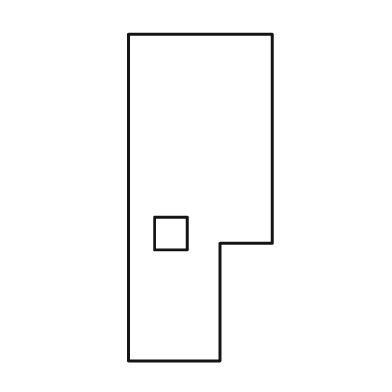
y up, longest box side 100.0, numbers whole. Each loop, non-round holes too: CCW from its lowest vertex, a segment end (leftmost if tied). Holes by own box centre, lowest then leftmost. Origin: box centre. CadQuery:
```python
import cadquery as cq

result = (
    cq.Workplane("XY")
    .moveTo(-22.0, -50.0)
    .lineTo(6.0, -50.0)
    .lineTo(6.0, -14.0)
    .lineTo(22.0, -14.0)
    .lineTo(22.0, 50.0)
    .lineTo(-22.0, 50.0)
    .close()
    .moveTo(-14.0, -16.0)
    .lineTo(-4.0, -16.0)
    .lineTo(-4.0, -6.0)
    .lineTo(-14.0, -6.0)
    .close()
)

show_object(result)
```